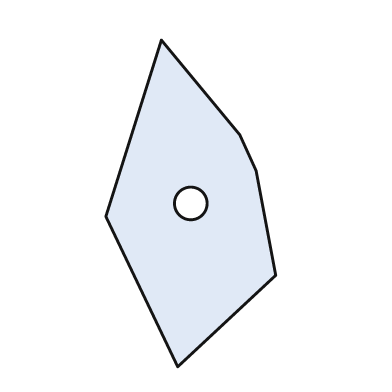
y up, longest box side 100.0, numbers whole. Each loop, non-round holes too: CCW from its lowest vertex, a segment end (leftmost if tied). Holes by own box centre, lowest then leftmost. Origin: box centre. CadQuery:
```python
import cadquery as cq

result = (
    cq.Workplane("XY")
    .moveTo(-4.0, -50.0)
    .lineTo(26.0, -22.0)
    .lineTo(20.0, 10.0)
    .lineTo(15.0, 21.0)
    .lineTo(-9.0, 50.0)
    .lineTo(-26.0, -4.0)
    .close()
    .moveTo(0.0, 0.0)
    .circle(5.0)
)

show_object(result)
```